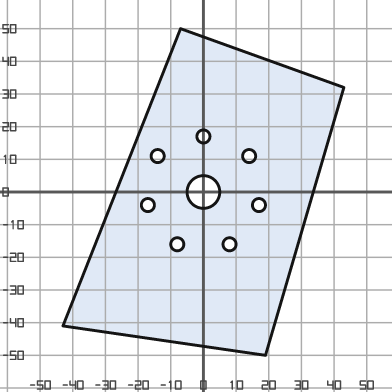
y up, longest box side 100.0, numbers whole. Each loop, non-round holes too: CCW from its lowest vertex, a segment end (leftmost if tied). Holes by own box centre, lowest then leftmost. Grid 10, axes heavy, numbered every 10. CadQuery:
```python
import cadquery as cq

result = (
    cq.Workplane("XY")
    .moveTo(19.0, -50.0)
    .lineTo(43.0, 32.0)
    .lineTo(-7.0, 50.0)
    .lineTo(-43.0, -41.0)
    .close()
    .moveTo(-8.0, -16.0)
    .circle(2.0)
    .moveTo(8.0, -16.0)
    .circle(2.0)
    .moveTo(-17.0, -4.0)
    .circle(2.0)
    .moveTo(17.0, -4.0)
    .circle(2.0)
    .moveTo(0.0, 0.0)
    .circle(5.0)
    .moveTo(-14.0, 11.0)
    .circle(2.0)
    .moveTo(14.0, 11.0)
    .circle(2.0)
    .moveTo(0.0, 17.0)
    .circle(2.0)
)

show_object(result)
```